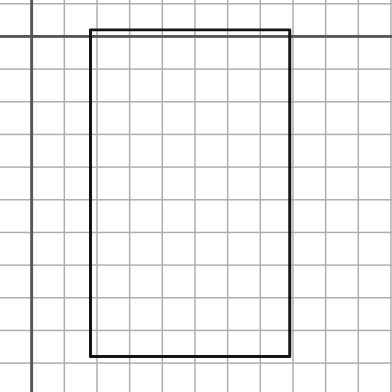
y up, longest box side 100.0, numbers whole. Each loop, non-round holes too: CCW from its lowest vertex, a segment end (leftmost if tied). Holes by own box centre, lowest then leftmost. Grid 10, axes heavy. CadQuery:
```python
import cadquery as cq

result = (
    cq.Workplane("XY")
    .moveTo(18.0, -98.0)
    .lineTo(79.0, -98.0)
    .lineTo(79.0, 2.0)
    .lineTo(18.0, 2.0)
    .close()
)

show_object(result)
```